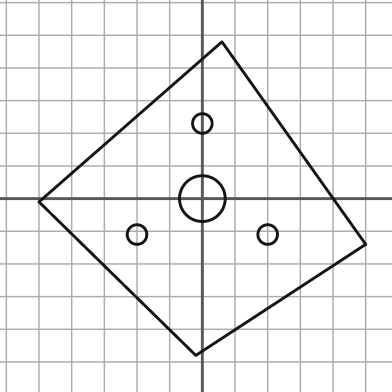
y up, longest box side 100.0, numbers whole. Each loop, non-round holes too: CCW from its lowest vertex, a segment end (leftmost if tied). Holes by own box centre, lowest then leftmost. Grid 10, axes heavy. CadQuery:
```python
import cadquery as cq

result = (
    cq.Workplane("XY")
    .moveTo(-2.0, -48.0)
    .lineTo(50.0, -14.0)
    .lineTo(6.0, 48.0)
    .lineTo(-50.0, -1.0)
    .close()
    .moveTo(-20.0, -11.0)
    .circle(3.0)
    .moveTo(20.0, -11.0)
    .circle(3.0)
    .moveTo(0.0, 0.0)
    .circle(7.0)
    .moveTo(0.0, 23.0)
    .circle(3.0)
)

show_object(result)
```